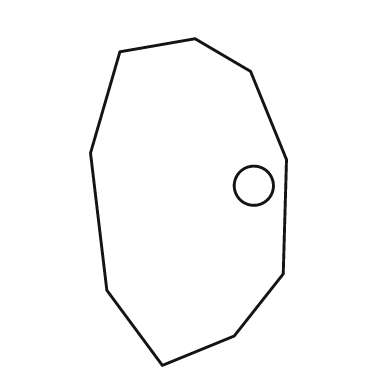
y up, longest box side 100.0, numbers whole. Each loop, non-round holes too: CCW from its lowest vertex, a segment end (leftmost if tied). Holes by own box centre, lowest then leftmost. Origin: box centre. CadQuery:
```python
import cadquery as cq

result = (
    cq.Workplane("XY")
    .moveTo(-8.0, -50.0)
    .lineTo(14.0, -41.0)
    .lineTo(29.0, -22.0)
    .lineTo(30.0, 13.0)
    .lineTo(19.0, 40.0)
    .lineTo(2.0, 50.0)
    .lineTo(-21.0, 46.0)
    .lineTo(-30.0, 15.0)
    .lineTo(-25.0, -27.0)
    .close()
    .moveTo(20.0, 5.0)
    .circle(6.0)
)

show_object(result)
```